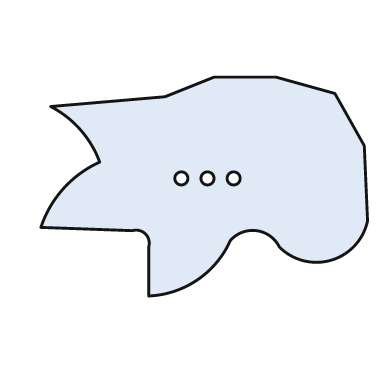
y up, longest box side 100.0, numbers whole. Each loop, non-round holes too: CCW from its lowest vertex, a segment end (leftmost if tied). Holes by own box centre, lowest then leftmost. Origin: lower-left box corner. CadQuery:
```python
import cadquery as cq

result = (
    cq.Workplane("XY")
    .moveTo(33.0, 0.0)
    .threePointArc((48.0, 5.0), (58.0, 17.0))
    .threePointArc((66.0, 20.0), (73.0, 15.0))
    .threePointArc((89.0, 11.0), (100.0, 23.0))
    .lineTo(99.0, 46.0)
    .lineTo(90.0, 62.0)
    .lineTo(72.0, 67.0)
    .lineTo(53.0, 67.0)
    .lineTo(38.0, 61.0)
    .lineTo(3.0, 58.0)
    .threePointArc((12.0, 51.0), (18.0, 41.0))
    .threePointArc((7.0, 33.0), (0.0, 21.0))
    .lineTo(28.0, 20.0)
    .threePointArc((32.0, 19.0), (33.0, 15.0))
    .close()
    .moveTo(43.0, 36.0)
    .circle(2.0)
    .moveTo(51.0, 36.0)
    .circle(2.0)
    .moveTo(59.0, 36.0)
    .circle(2.0)
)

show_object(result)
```